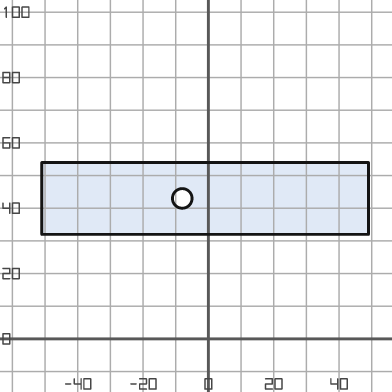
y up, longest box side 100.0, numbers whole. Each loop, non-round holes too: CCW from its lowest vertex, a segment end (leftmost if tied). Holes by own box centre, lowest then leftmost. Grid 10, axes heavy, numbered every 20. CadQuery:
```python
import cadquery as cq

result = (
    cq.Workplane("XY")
    .moveTo(-51.0, 32.0)
    .lineTo(49.0, 32.0)
    .lineTo(49.0, 54.0)
    .lineTo(-51.0, 54.0)
    .close()
    .moveTo(-8.0, 43.0)
    .circle(3.0)
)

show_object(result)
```